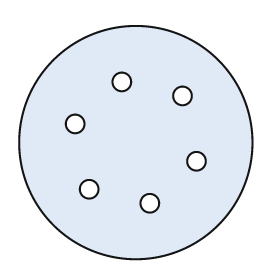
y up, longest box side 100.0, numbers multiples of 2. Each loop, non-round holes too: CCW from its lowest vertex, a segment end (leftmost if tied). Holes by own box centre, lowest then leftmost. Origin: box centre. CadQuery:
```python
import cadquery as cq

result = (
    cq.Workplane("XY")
    .moveTo(0.0, 0.0)
    .circle(50.0)
    .moveTo(6.0, -26.0)
    .circle(4.0)
    .moveTo(-20.0, -20.0)
    .circle(4.0)
    .moveTo(26.0, -8.0)
    .circle(4.0)
    .moveTo(-26.0, 8.0)
    .circle(4.0)
    .moveTo(20.0, 20.0)
    .circle(4.0)
    .moveTo(-6.0, 26.0)
    .circle(4.0)
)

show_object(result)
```